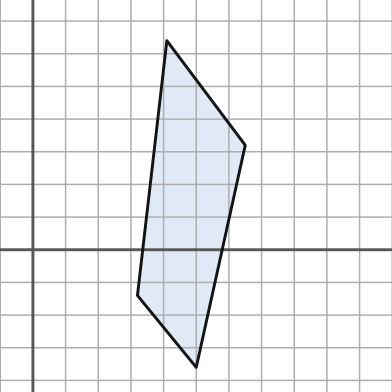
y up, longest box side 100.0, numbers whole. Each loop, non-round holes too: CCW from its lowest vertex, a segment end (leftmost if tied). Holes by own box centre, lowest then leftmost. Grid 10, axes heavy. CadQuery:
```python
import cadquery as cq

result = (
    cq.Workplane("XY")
    .moveTo(50.0, -36.0)
    .lineTo(65.0, 32.0)
    .lineTo(41.0, 64.0)
    .lineTo(32.0, -14.0)
    .close()
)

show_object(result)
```